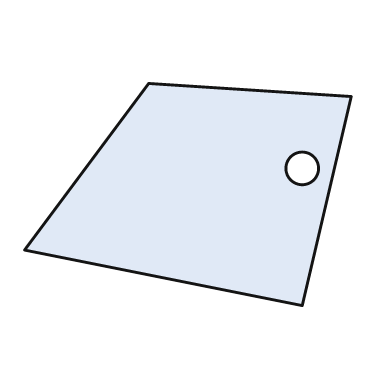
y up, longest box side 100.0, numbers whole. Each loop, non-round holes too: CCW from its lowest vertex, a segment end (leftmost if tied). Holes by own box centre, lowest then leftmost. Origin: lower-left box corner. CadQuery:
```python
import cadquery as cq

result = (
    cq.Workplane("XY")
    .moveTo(85.0, 0.0)
    .lineTo(100.0, 64.0)
    .lineTo(38.0, 68.0)
    .lineTo(0.0, 17.0)
    .close()
    .moveTo(85.0, 42.0)
    .circle(5.0)
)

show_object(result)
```